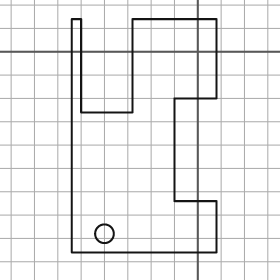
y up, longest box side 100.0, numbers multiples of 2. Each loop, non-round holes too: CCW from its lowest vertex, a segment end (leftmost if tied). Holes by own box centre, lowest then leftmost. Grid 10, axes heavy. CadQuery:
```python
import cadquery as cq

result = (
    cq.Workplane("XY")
    .moveTo(-54.0, -86.0)
    .lineTo(8.0, -86.0)
    .lineTo(8.0, -64.0)
    .lineTo(-10.0, -64.0)
    .lineTo(-10.0, -20.0)
    .lineTo(8.0, -20.0)
    .lineTo(8.0, 14.0)
    .lineTo(-28.0, 14.0)
    .lineTo(-28.0, -26.0)
    .lineTo(-50.0, -26.0)
    .lineTo(-50.0, 14.0)
    .lineTo(-54.0, 14.0)
    .close()
    .moveTo(-40.0, -78.0)
    .circle(4.0)
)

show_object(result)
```